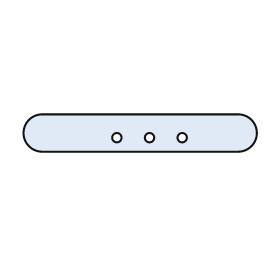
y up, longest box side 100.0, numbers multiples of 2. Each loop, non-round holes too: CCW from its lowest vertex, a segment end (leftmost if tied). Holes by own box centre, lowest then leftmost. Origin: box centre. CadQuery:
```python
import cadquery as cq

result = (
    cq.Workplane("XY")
    .moveTo(-42.0, -8.0)
    .lineTo(42.0, -8.0)
    .threePointArc((50.0, 0.0), (42.0, 8.0))
    .lineTo(-42.0, 8.0)
    .threePointArc((-50.0, 0.0), (-42.0, -8.0))
    .close()
    .moveTo(-10.0, -2.0)
    .circle(2.0)
    .moveTo(4.0, -2.0)
    .circle(2.0)
    .moveTo(18.0, -2.0)
    .circle(2.0)
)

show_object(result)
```